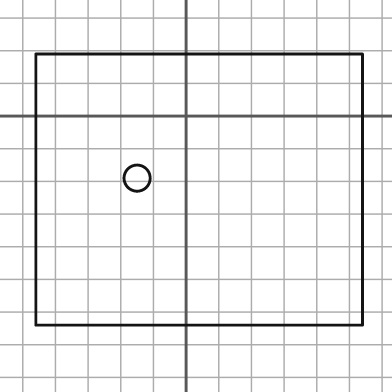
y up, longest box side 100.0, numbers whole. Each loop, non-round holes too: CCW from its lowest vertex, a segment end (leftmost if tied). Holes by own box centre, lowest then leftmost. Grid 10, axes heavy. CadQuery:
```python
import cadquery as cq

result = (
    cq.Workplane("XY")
    .moveTo(-46.0, -64.0)
    .lineTo(54.0, -64.0)
    .lineTo(54.0, 19.0)
    .lineTo(-46.0, 19.0)
    .close()
    .moveTo(-15.0, -19.0)
    .circle(4.0)
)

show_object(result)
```